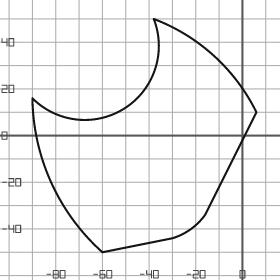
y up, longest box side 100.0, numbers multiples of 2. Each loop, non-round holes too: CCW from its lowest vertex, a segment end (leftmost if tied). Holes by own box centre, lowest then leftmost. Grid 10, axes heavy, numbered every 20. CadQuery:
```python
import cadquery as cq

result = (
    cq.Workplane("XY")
    .moveTo(-60.0, -50.0)
    .lineTo(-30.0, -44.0)
    .threePointArc((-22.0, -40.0), (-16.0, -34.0))
    .lineTo(6.0, 10.0)
    .threePointArc((-12.0, 34.0), (-38.0, 50.0))
    .threePointArc((-50.0, 12.0), (-90.0, 16.0))
    .threePointArc((-82.0, -20.0), (-60.0, -50.0))
    .close()
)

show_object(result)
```